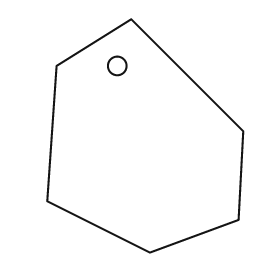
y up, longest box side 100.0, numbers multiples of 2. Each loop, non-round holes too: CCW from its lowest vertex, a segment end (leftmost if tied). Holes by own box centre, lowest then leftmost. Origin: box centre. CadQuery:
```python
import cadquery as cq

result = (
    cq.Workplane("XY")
    .moveTo(2.0, -50.0)
    .lineTo(40.0, -36.0)
    .lineTo(42.0, 2.0)
    .lineTo(-6.0, 50.0)
    .lineTo(-38.0, 30.0)
    .lineTo(-42.0, -28.0)
    .close()
    .moveTo(-12.0, 30.0)
    .circle(4.0)
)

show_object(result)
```